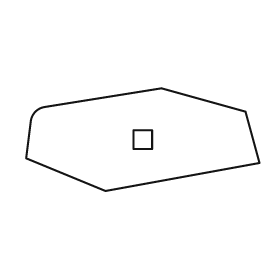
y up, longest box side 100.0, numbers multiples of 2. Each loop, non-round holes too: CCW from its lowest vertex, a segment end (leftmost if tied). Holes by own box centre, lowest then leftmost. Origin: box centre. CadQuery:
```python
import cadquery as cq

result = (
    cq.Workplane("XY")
    .moveTo(-16.0, -22.0)
    .lineTo(50.0, -10.0)
    .lineTo(44.0, 12.0)
    .lineTo(8.0, 22.0)
    .lineTo(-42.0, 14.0)
    .threePointArc((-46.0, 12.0), (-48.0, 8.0))
    .lineTo(-50.0, -8.0)
    .close()
    .moveTo(-4.0, -4.0)
    .lineTo(4.0, -4.0)
    .lineTo(4.0, 4.0)
    .lineTo(-4.0, 4.0)
    .close()
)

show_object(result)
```